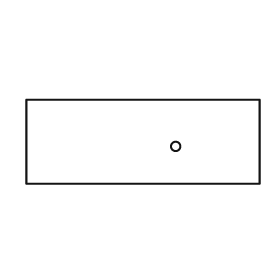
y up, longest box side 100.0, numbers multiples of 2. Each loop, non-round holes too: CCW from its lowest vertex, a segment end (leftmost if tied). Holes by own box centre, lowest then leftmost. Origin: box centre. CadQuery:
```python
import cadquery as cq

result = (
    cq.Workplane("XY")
    .moveTo(-50.0, -18.0)
    .lineTo(50.0, -18.0)
    .lineTo(50.0, 18.0)
    .lineTo(-50.0, 18.0)
    .close()
    .moveTo(14.0, -2.0)
    .circle(2.0)
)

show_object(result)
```